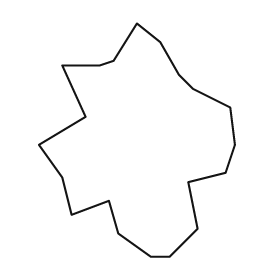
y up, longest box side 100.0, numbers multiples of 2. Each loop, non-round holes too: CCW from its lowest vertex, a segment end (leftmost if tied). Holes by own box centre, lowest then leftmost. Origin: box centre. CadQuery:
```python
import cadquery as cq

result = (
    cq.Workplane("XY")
    .moveTo(6.0, -50.0)
    .lineTo(14.0, -50.0)
    .lineTo(26.0, -38.0)
    .lineTo(22.0, -18.0)
    .lineTo(38.0, -14.0)
    .lineTo(42.0, -2.0)
    .lineTo(40.0, 14.0)
    .lineTo(24.0, 22.0)
    .lineTo(18.0, 28.0)
    .lineTo(10.0, 42.0)
    .lineTo(0.0, 50.0)
    .lineTo(-10.0, 34.0)
    .lineTo(-16.0, 32.0)
    .lineTo(-32.0, 32.0)
    .lineTo(-22.0, 10.0)
    .lineTo(-42.0, -2.0)
    .lineTo(-32.0, -16.0)
    .lineTo(-28.0, -32.0)
    .lineTo(-12.0, -26.0)
    .lineTo(-8.0, -40.0)
    .close()
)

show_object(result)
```